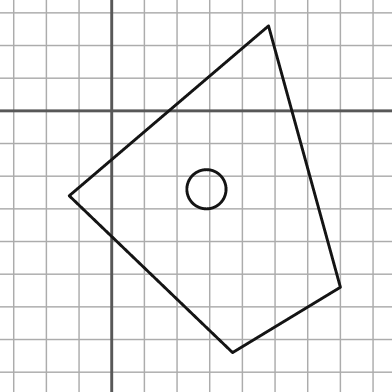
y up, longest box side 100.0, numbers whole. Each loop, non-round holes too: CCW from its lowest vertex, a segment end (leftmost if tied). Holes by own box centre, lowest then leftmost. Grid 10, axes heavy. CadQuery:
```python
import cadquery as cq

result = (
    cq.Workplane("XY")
    .moveTo(37.0, -74.0)
    .lineTo(70.0, -54.0)
    .lineTo(48.0, 26.0)
    .lineTo(-13.0, -26.0)
    .close()
    .moveTo(29.0, -24.0)
    .circle(6.0)
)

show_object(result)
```